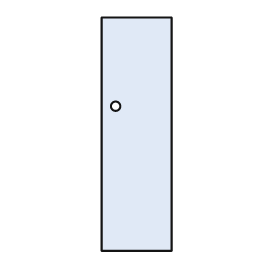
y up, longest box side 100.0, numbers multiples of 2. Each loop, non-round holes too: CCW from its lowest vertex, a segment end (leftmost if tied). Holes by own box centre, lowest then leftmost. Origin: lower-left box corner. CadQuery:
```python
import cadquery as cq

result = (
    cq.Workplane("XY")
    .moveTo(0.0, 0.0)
    .lineTo(30.0, 0.0)
    .lineTo(30.0, 100.0)
    .lineTo(0.0, 100.0)
    .close()
    .moveTo(6.0, 62.0)
    .circle(2.0)
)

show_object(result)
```